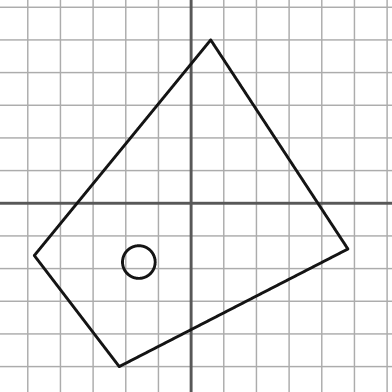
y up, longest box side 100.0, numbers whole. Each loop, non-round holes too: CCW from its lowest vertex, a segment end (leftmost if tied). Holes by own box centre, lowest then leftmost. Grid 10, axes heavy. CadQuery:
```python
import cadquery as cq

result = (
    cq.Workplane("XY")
    .moveTo(-22.0, -50.0)
    .lineTo(48.0, -14.0)
    .lineTo(6.0, 50.0)
    .lineTo(-48.0, -16.0)
    .close()
    .moveTo(-16.0, -18.0)
    .circle(5.0)
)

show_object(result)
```